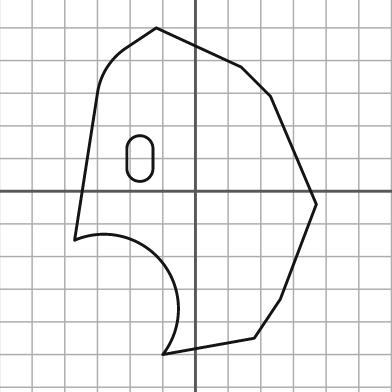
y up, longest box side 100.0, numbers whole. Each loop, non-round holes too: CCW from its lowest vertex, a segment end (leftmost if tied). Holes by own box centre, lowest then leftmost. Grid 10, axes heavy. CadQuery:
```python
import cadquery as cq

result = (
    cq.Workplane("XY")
    .moveTo(-10.0, -50.0)
    .lineTo(18.0, -45.0)
    .lineTo(26.0, -33.0)
    .lineTo(37.0, -4.0)
    .lineTo(23.0, 29.0)
    .lineTo(14.0, 38.0)
    .lineTo(-12.0, 50.0)
    .lineTo(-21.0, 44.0)
    .threePointArc((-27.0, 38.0), (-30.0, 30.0))
    .lineTo(-37.0, -15.0)
    .threePointArc((-10.0, -22.0), (-10.0, -50.0))
    .close()
    .moveTo(-21.0, 7.0)
    .threePointArc((-17.0, 3.0), (-13.0, 7.0))
    .lineTo(-13.0, 13.0)
    .threePointArc((-17.0, 17.0), (-21.0, 13.0))
    .close()
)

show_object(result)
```